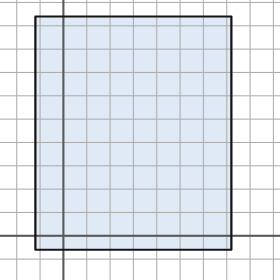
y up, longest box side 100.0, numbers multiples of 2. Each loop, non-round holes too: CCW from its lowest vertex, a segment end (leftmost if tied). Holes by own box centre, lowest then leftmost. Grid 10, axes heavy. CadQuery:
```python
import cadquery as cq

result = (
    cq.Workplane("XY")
    .moveTo(-12.0, -6.0)
    .lineTo(72.0, -6.0)
    .lineTo(72.0, 94.0)
    .lineTo(-12.0, 94.0)
    .close()
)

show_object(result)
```